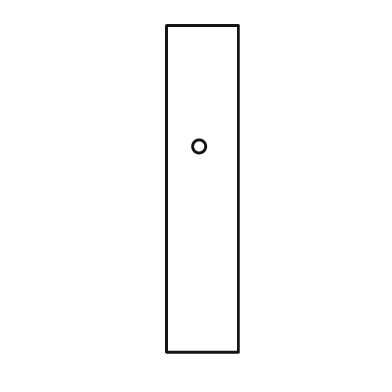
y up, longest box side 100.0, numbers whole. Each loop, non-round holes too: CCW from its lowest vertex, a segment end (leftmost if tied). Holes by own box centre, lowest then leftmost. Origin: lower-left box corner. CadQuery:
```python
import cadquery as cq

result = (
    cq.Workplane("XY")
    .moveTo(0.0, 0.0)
    .lineTo(22.0, 0.0)
    .lineTo(22.0, 100.0)
    .lineTo(0.0, 100.0)
    .close()
    .moveTo(10.0, 63.0)
    .circle(2.0)
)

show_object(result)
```